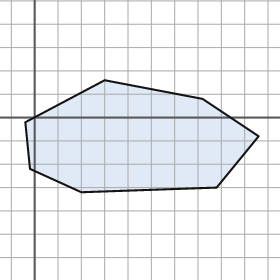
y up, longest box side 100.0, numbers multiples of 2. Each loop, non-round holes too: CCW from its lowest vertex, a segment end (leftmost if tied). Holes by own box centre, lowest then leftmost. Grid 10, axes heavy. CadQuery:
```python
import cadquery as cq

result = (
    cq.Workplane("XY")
    .moveTo(20.0, -32.0)
    .lineTo(78.0, -30.0)
    .lineTo(96.0, -8.0)
    .lineTo(72.0, 8.0)
    .lineTo(30.0, 16.0)
    .lineTo(-4.0, -2.0)
    .lineTo(-2.0, -22.0)
    .close()
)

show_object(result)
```